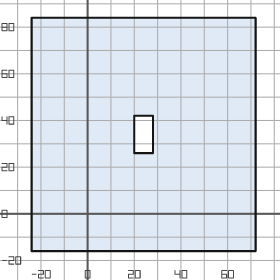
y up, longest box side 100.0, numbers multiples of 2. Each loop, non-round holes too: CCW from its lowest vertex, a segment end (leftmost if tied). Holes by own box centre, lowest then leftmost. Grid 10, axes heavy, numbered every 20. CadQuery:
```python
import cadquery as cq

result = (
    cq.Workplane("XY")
    .moveTo(-24.0, -16.0)
    .lineTo(72.0, -16.0)
    .lineTo(72.0, 84.0)
    .lineTo(-24.0, 84.0)
    .close()
    .moveTo(20.0, 26.0)
    .lineTo(28.0, 26.0)
    .lineTo(28.0, 42.0)
    .lineTo(20.0, 42.0)
    .close()
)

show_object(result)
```